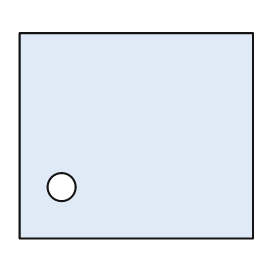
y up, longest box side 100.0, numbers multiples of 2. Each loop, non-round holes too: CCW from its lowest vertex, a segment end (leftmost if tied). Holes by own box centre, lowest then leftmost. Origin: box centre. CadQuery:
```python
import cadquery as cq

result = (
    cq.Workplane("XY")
    .moveTo(-50.0, -44.0)
    .lineTo(50.0, -44.0)
    .lineTo(50.0, 44.0)
    .lineTo(-50.0, 44.0)
    .close()
    .moveTo(-32.0, -22.0)
    .circle(6.0)
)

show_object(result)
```